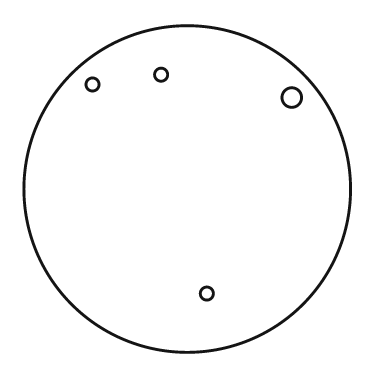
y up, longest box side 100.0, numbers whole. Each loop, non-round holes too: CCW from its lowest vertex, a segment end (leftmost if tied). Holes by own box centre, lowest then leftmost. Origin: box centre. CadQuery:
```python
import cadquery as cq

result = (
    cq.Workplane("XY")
    .moveTo(0.0, 0.0)
    .circle(50.0)
    .moveTo(6.0, -32.0)
    .circle(2.0)
    .moveTo(32.0, 28.0)
    .circle(3.0)
    .moveTo(-29.0, 32.0)
    .circle(2.0)
    .moveTo(-8.0, 35.0)
    .circle(2.0)
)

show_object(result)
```